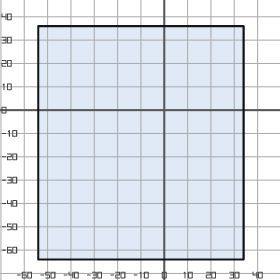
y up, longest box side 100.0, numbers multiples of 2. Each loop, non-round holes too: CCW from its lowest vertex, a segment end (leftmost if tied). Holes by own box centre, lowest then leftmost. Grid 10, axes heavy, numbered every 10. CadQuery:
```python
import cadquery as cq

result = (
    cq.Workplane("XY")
    .moveTo(-54.0, -64.0)
    .lineTo(34.0, -64.0)
    .lineTo(34.0, 36.0)
    .lineTo(-54.0, 36.0)
    .close()
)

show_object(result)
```